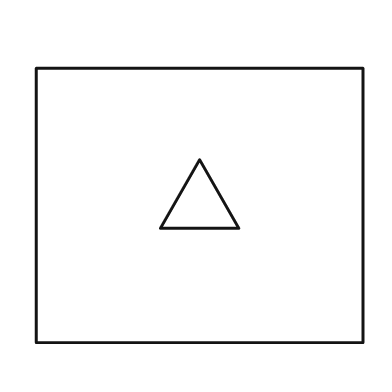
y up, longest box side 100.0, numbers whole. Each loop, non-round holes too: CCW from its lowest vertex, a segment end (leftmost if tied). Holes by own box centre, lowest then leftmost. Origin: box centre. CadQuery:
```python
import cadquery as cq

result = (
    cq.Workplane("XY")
    .moveTo(-50.0, -42.0)
    .lineTo(50.0, -42.0)
    .lineTo(50.0, 42.0)
    .lineTo(-50.0, 42.0)
    .close()
    .moveTo(-12.0, -7.0)
    .lineTo(12.0, -7.0)
    .lineTo(0.0, 14.0)
    .close()
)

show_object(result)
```